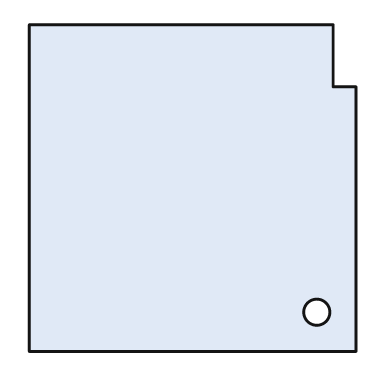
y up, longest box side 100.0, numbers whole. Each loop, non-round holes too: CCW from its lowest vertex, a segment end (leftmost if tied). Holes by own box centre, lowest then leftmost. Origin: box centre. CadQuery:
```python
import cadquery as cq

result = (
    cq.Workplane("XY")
    .moveTo(-50.0, -50.0)
    .lineTo(50.0, -50.0)
    .lineTo(50.0, 31.0)
    .lineTo(43.0, 31.0)
    .lineTo(43.0, 50.0)
    .lineTo(-50.0, 50.0)
    .close()
    .moveTo(38.0, -38.0)
    .circle(4.0)
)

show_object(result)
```